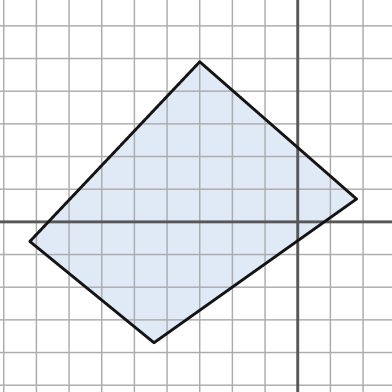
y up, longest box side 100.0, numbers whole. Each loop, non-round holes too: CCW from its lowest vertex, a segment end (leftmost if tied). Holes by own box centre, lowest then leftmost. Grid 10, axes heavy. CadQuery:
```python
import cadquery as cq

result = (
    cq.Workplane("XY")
    .moveTo(-44.0, -37.0)
    .lineTo(18.0, 7.0)
    .lineTo(-30.0, 49.0)
    .lineTo(-82.0, -6.0)
    .close()
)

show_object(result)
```